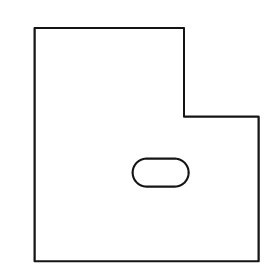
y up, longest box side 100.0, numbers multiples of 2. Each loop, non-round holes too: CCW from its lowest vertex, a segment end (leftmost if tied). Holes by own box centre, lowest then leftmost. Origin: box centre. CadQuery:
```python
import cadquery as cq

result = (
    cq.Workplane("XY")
    .moveTo(-48.0, -50.0)
    .lineTo(48.0, -50.0)
    .lineTo(48.0, 12.0)
    .lineTo(16.0, 12.0)
    .lineTo(16.0, 50.0)
    .lineTo(-48.0, 50.0)
    .close()
    .moveTo(0.0, -18.0)
    .lineTo(12.0, -18.0)
    .threePointArc((18.0, -12.0), (12.0, -6.0))
    .lineTo(0.0, -6.0)
    .threePointArc((-6.0, -12.0), (0.0, -18.0))
    .close()
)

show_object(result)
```